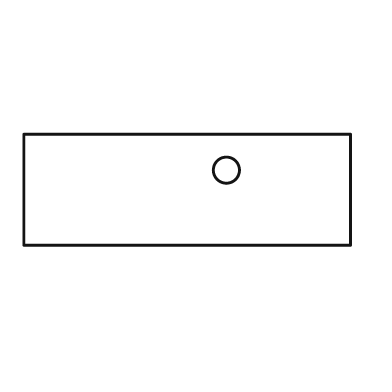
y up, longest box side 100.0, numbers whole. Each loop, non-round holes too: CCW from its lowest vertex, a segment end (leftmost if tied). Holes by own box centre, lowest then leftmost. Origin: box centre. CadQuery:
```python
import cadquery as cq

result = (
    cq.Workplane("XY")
    .moveTo(-50.0, -17.0)
    .lineTo(50.0, -17.0)
    .lineTo(50.0, 17.0)
    .lineTo(-50.0, 17.0)
    .close()
    .moveTo(12.0, 6.0)
    .circle(4.0)
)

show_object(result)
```